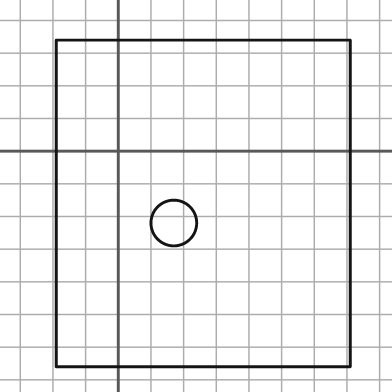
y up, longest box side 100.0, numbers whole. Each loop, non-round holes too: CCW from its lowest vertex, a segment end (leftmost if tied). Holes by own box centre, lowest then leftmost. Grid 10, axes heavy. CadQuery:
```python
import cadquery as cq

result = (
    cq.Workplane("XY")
    .moveTo(-19.0, -66.0)
    .lineTo(71.0, -66.0)
    .lineTo(71.0, 34.0)
    .lineTo(-19.0, 34.0)
    .close()
    .moveTo(17.0, -22.0)
    .circle(7.0)
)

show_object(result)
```